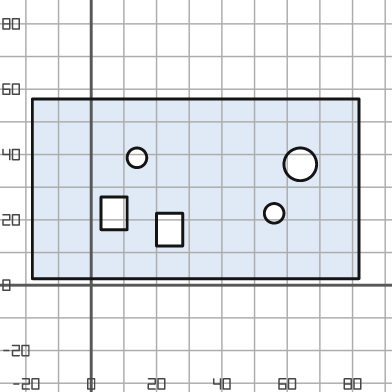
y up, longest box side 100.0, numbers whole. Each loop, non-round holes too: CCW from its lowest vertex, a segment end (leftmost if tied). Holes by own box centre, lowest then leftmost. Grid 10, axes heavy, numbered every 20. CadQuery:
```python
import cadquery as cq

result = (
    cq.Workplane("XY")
    .moveTo(-18.0, 2.0)
    .lineTo(82.0, 2.0)
    .lineTo(82.0, 57.0)
    .lineTo(-18.0, 57.0)
    .close()
    .moveTo(20.0, 12.0)
    .lineTo(28.0, 12.0)
    .lineTo(28.0, 22.0)
    .lineTo(20.0, 22.0)
    .close()
    .moveTo(3.0, 17.0)
    .lineTo(11.0, 17.0)
    .lineTo(11.0, 27.0)
    .lineTo(3.0, 27.0)
    .close()
    .moveTo(56.0, 22.0)
    .circle(3.0)
    .moveTo(64.0, 37.0)
    .circle(5.0)
    .moveTo(14.0, 39.0)
    .circle(3.0)
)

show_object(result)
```